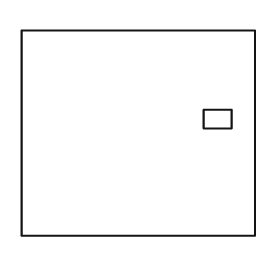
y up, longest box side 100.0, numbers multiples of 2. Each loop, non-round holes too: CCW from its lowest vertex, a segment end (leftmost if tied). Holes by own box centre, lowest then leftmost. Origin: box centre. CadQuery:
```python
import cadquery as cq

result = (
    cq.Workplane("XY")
    .moveTo(-50.0, -44.0)
    .lineTo(50.0, -44.0)
    .lineTo(50.0, 44.0)
    .lineTo(-50.0, 44.0)
    .close()
    .moveTo(28.0, 2.0)
    .lineTo(40.0, 2.0)
    .lineTo(40.0, 10.0)
    .lineTo(28.0, 10.0)
    .close()
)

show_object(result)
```